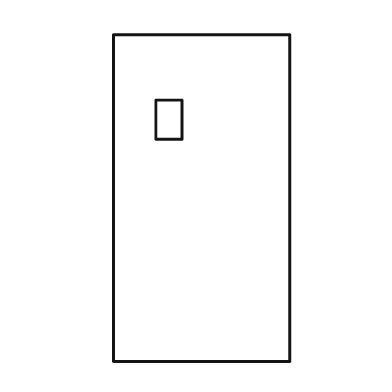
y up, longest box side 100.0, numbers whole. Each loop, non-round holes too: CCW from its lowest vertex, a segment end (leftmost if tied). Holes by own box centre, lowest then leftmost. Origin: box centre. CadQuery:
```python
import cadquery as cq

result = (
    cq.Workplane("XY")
    .moveTo(-27.0, -50.0)
    .lineTo(27.0, -50.0)
    .lineTo(27.0, 50.0)
    .lineTo(-27.0, 50.0)
    .close()
    .moveTo(-14.0, 18.0)
    .lineTo(-6.0, 18.0)
    .lineTo(-6.0, 30.0)
    .lineTo(-14.0, 30.0)
    .close()
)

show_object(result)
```